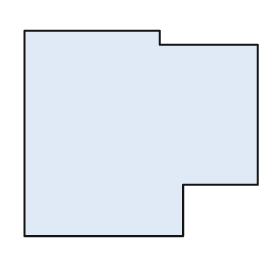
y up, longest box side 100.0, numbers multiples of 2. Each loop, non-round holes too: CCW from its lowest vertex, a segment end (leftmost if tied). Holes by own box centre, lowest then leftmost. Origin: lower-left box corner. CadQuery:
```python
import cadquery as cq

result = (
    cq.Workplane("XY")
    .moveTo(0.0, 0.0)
    .lineTo(68.0, 0.0)
    .lineTo(68.0, 22.0)
    .lineTo(100.0, 22.0)
    .lineTo(100.0, 82.0)
    .lineTo(58.0, 82.0)
    .lineTo(58.0, 88.0)
    .lineTo(0.0, 88.0)
    .close()
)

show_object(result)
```